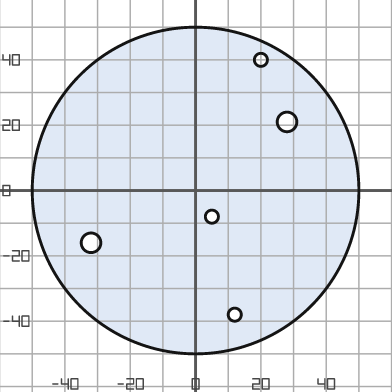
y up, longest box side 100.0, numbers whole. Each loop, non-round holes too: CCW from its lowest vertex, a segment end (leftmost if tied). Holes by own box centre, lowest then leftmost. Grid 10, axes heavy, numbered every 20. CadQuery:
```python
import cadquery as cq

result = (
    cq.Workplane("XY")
    .moveTo(0.0, 0.0)
    .circle(50.0)
    .moveTo(12.0, -38.0)
    .circle(2.0)
    .moveTo(-32.0, -16.0)
    .circle(3.0)
    .moveTo(5.0, -8.0)
    .circle(2.0)
    .moveTo(28.0, 21.0)
    .circle(3.0)
    .moveTo(20.0, 40.0)
    .circle(2.0)
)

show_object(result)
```